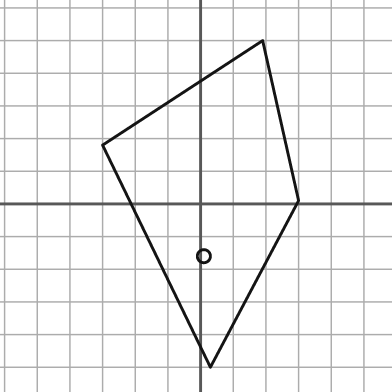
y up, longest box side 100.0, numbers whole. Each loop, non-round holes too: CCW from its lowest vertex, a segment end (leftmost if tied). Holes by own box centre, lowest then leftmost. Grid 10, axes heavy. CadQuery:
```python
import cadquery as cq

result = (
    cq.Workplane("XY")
    .moveTo(3.0, -50.0)
    .lineTo(30.0, 1.0)
    .lineTo(19.0, 50.0)
    .lineTo(-30.0, 18.0)
    .close()
    .moveTo(1.0, -16.0)
    .circle(2.0)
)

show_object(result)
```